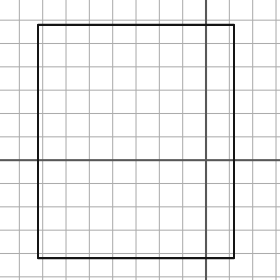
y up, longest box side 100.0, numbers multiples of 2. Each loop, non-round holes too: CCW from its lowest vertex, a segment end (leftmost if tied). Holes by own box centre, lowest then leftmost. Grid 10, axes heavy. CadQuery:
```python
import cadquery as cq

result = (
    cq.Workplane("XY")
    .moveTo(-72.0, -42.0)
    .lineTo(12.0, -42.0)
    .lineTo(12.0, 58.0)
    .lineTo(-72.0, 58.0)
    .close()
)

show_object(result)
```